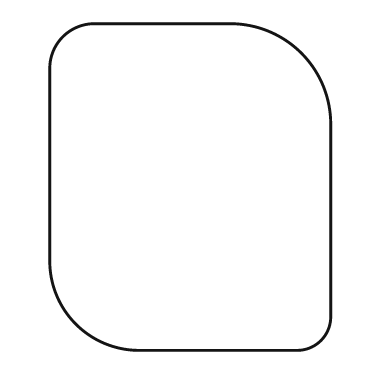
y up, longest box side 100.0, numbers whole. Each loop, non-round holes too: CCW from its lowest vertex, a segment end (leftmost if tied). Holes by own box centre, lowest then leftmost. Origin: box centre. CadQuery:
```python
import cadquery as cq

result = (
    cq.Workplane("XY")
    .moveTo(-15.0, -50.0)
    .lineTo(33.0, -50.0)
    .threePointArc((40.0, -47.0), (43.0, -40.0))
    .lineTo(43.0, 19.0)
    .threePointArc((34.0, 41.0), (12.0, 50.0))
    .lineTo(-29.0, 50.0)
    .threePointArc((-39.0, 46.0), (-43.0, 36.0))
    .lineTo(-43.0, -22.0)
    .threePointArc((-35.0, -42.0), (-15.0, -50.0))
    .close()
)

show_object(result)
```